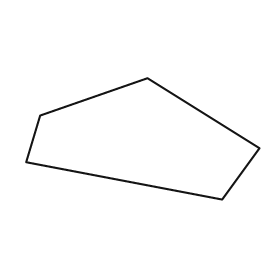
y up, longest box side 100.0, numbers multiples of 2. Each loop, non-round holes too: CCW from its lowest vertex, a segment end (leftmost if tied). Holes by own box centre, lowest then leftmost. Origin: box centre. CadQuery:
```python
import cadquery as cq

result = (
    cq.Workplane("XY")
    .moveTo(34.0, -26.0)
    .lineTo(50.0, -4.0)
    .lineTo(2.0, 26.0)
    .lineTo(-44.0, 10.0)
    .lineTo(-50.0, -10.0)
    .close()
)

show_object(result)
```